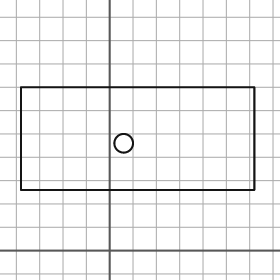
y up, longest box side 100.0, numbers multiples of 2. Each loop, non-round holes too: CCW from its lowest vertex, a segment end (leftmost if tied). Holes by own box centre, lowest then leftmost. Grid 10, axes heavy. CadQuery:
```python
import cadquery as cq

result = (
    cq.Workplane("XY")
    .moveTo(-38.0, 26.0)
    .lineTo(62.0, 26.0)
    .lineTo(62.0, 70.0)
    .lineTo(-38.0, 70.0)
    .close()
    .moveTo(6.0, 46.0)
    .circle(4.0)
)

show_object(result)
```